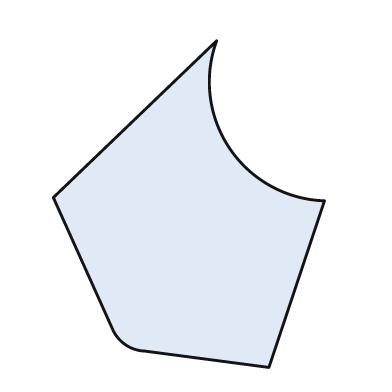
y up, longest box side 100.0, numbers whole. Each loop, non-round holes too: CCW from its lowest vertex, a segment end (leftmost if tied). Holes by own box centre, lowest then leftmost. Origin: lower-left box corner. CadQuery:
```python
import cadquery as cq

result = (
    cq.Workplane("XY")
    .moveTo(66.0, 0.0)
    .lineTo(83.0, 51.0)
    .threePointArc((54.0, 67.0), (50.0, 100.0))
    .lineTo(0.0, 52.0)
    .lineTo(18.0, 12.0)
    .threePointArc((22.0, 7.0), (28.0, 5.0))
    .close()
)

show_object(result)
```